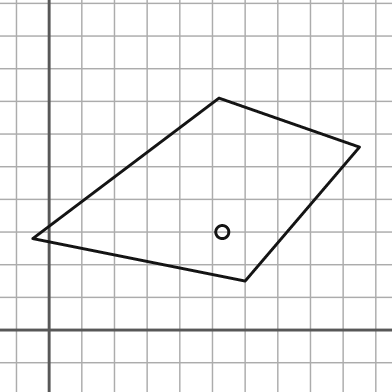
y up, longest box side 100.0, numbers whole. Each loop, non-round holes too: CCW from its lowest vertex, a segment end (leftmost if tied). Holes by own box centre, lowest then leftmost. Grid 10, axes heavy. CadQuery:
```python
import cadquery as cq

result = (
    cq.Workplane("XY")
    .moveTo(60.0, 15.0)
    .lineTo(95.0, 56.0)
    .lineTo(52.0, 71.0)
    .lineTo(-5.0, 28.0)
    .close()
    .moveTo(53.0, 30.0)
    .circle(2.0)
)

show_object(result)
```